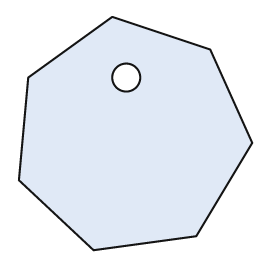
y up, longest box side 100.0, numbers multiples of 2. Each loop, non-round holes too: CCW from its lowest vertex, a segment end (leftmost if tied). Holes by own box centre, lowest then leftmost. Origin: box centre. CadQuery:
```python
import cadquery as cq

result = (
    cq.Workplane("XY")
    .moveTo(-18.0, -50.0)
    .lineTo(26.0, -44.0)
    .lineTo(50.0, -4.0)
    .lineTo(32.0, 36.0)
    .lineTo(-10.0, 50.0)
    .lineTo(-46.0, 24.0)
    .lineTo(-50.0, -20.0)
    .close()
    .moveTo(-4.0, 24.0)
    .circle(6.0)
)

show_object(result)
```